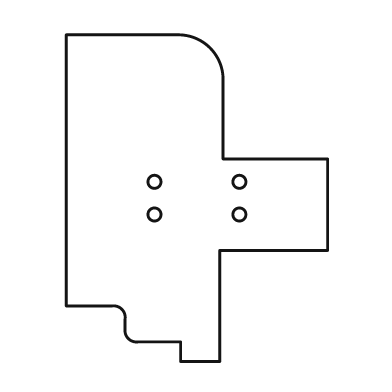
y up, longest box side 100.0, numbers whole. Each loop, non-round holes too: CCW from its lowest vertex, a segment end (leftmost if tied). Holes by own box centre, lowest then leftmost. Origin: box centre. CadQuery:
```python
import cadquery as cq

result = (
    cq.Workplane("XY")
    .moveTo(-5.0, -50.0)
    .lineTo(7.0, -50.0)
    .lineTo(7.0, -16.0)
    .lineTo(40.0, -16.0)
    .lineTo(40.0, 12.0)
    .lineTo(8.0, 12.0)
    .lineTo(8.0, 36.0)
    .threePointArc((4.0, 46.0), (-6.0, 50.0))
    .lineTo(-40.0, 50.0)
    .lineTo(-40.0, -33.0)
    .lineTo(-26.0, -33.0)
    .threePointArc((-23.0, -34.0), (-22.0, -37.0))
    .lineTo(-22.0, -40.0)
    .threePointArc((-21.0, -43.0), (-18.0, -44.0))
    .lineTo(-5.0, -44.0)
    .close()
    .moveTo(-13.0, -5.0)
    .circle(2.0)
    .moveTo(13.0, -5.0)
    .circle(2.0)
    .moveTo(-13.0, 5.0)
    .circle(2.0)
    .moveTo(13.0, 5.0)
    .circle(2.0)
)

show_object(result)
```